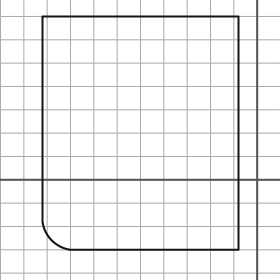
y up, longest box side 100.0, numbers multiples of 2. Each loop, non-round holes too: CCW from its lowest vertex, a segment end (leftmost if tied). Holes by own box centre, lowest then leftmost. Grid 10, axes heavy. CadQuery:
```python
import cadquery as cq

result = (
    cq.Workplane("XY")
    .moveTo(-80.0, -30.0)
    .lineTo(-8.0, -30.0)
    .lineTo(-8.0, 70.0)
    .lineTo(-92.0, 70.0)
    .lineTo(-92.0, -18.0)
    .threePointArc((-88.0, -26.0), (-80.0, -30.0))
    .close()
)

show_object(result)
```